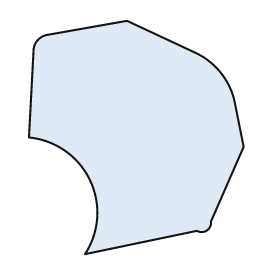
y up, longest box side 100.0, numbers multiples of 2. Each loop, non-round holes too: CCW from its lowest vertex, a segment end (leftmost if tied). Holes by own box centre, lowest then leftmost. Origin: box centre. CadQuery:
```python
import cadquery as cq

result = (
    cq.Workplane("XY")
    .moveTo(-22.0, -50.0)
    .lineTo(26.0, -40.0)
    .threePointArc((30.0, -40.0), (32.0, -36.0))
    .lineTo(46.0, -4.0)
    .lineTo(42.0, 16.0)
    .threePointArc((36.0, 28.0), (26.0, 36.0))
    .lineTo(-4.0, 50.0)
    .lineTo(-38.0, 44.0)
    .threePointArc((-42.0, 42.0), (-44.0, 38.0))
    .lineTo(-46.0, 0.0)
    .threePointArc((-20.0, -18.0), (-22.0, -50.0))
    .close()
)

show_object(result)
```